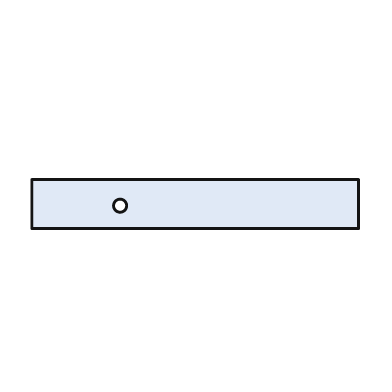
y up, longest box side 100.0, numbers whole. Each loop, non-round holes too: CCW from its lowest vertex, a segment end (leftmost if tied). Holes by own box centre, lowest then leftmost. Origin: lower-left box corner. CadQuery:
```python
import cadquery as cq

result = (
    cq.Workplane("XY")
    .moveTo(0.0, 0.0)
    .lineTo(100.0, 0.0)
    .lineTo(100.0, 15.0)
    .lineTo(0.0, 15.0)
    .close()
    .moveTo(27.0, 7.0)
    .circle(2.0)
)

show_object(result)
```